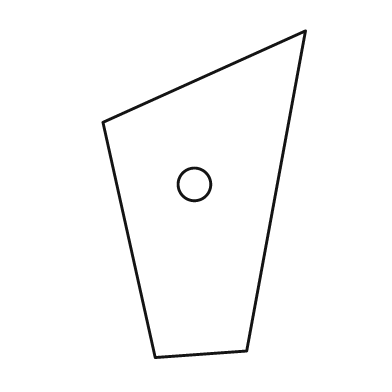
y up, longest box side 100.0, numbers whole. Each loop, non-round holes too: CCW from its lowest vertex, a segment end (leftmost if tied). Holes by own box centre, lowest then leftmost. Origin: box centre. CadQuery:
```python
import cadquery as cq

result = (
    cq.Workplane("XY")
    .moveTo(-15.0, -50.0)
    .lineTo(13.0, -48.0)
    .lineTo(31.0, 50.0)
    .lineTo(-31.0, 22.0)
    .close()
    .moveTo(-3.0, 3.0)
    .circle(5.0)
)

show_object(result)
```